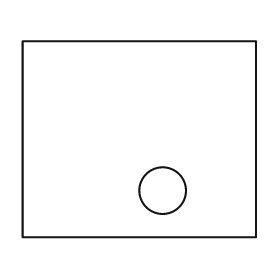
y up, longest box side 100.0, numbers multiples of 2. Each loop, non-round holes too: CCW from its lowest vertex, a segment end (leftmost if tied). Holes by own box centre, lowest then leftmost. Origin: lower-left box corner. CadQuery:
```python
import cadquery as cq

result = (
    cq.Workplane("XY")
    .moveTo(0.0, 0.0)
    .lineTo(100.0, 0.0)
    .lineTo(100.0, 84.0)
    .lineTo(0.0, 84.0)
    .close()
    .moveTo(60.0, 20.0)
    .circle(10.0)
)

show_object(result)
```